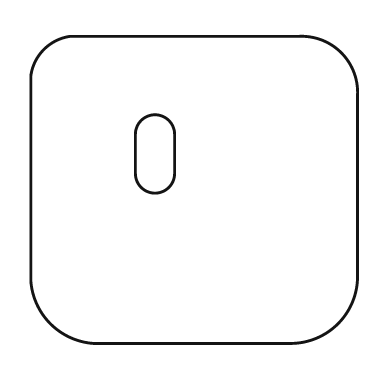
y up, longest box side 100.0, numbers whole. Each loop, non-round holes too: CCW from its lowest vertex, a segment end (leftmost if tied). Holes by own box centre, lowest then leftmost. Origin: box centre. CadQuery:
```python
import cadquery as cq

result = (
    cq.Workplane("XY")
    .moveTo(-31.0, -47.0)
    .lineTo(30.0, -47.0)
    .threePointArc((44.0, -41.0), (50.0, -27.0))
    .lineTo(50.0, 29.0)
    .threePointArc((45.0, 42.0), (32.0, 47.0))
    .lineTo(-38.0, 47.0)
    .threePointArc((-46.0, 43.0), (-50.0, 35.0))
    .lineTo(-50.0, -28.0)
    .threePointArc((-44.0, -41.0), (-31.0, -47.0))
    .close()
    .moveTo(-18.0, 5.0)
    .threePointArc((-12.0, -1.0), (-6.0, 5.0))
    .lineTo(-6.0, 17.0)
    .threePointArc((-12.0, 23.0), (-18.0, 17.0))
    .close()
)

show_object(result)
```